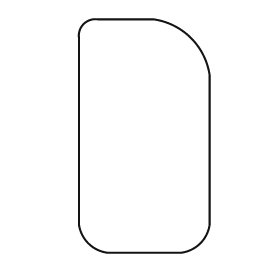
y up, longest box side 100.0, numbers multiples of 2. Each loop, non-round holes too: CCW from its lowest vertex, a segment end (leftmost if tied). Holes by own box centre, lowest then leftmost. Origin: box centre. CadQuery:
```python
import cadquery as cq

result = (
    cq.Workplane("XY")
    .moveTo(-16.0, -50.0)
    .lineTo(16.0, -50.0)
    .threePointArc((24.0, -46.0), (28.0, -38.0))
    .lineTo(28.0, 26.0)
    .threePointArc((20.0, 42.0), (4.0, 50.0))
    .lineTo(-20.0, 50.0)
    .threePointArc((-26.0, 48.0), (-28.0, 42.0))
    .lineTo(-28.0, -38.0)
    .threePointArc((-24.0, -46.0), (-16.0, -50.0))
    .close()
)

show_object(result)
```